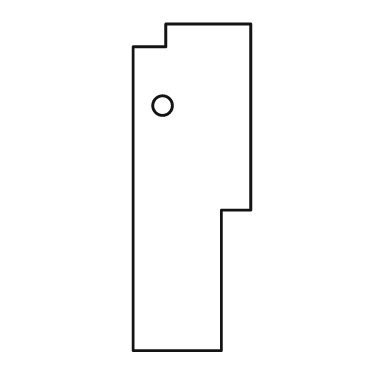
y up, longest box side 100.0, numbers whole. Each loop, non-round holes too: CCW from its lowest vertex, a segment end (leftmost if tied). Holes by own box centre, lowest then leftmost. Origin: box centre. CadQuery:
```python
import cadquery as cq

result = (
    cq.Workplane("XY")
    .moveTo(-18.0, -50.0)
    .lineTo(9.0, -50.0)
    .lineTo(9.0, -7.0)
    .lineTo(18.0, -7.0)
    .lineTo(18.0, 50.0)
    .lineTo(-8.0, 50.0)
    .lineTo(-8.0, 43.0)
    .lineTo(-18.0, 43.0)
    .close()
    .moveTo(-9.0, 25.0)
    .circle(3.0)
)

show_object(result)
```